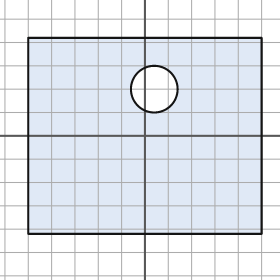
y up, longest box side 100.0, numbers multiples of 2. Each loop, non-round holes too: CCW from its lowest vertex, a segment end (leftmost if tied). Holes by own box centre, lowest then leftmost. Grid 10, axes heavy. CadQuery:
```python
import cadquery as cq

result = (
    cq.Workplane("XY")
    .moveTo(-50.0, -42.0)
    .lineTo(50.0, -42.0)
    .lineTo(50.0, 42.0)
    .lineTo(-50.0, 42.0)
    .close()
    .moveTo(4.0, 20.0)
    .circle(10.0)
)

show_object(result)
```